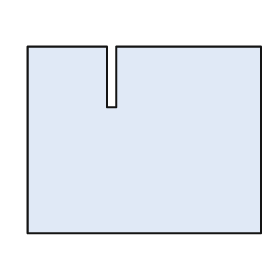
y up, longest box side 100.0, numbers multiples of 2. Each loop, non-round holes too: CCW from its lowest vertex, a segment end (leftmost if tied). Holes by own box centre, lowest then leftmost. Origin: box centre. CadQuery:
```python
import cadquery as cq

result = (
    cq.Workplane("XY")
    .moveTo(-50.0, -40.0)
    .lineTo(50.0, -40.0)
    .lineTo(50.0, 40.0)
    .lineTo(-12.0, 40.0)
    .lineTo(-12.0, 14.0)
    .lineTo(-16.0, 14.0)
    .lineTo(-16.0, 40.0)
    .lineTo(-50.0, 40.0)
    .close()
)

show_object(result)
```